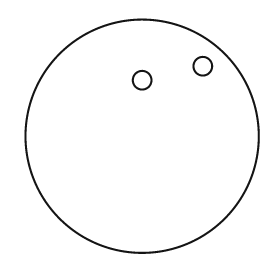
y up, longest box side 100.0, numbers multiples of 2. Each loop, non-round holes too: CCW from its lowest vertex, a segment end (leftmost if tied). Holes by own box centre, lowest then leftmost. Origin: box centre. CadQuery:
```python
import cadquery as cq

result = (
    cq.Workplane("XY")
    .moveTo(0.0, 0.0)
    .circle(50.0)
    .moveTo(0.0, 24.0)
    .circle(4.0)
    .moveTo(26.0, 30.0)
    .circle(4.0)
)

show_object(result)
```